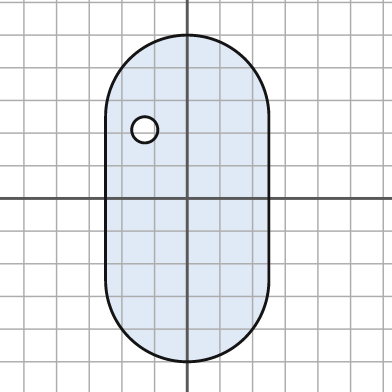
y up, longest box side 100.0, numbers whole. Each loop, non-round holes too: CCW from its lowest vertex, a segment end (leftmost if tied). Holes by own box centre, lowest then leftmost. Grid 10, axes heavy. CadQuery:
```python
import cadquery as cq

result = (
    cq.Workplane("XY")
    .moveTo(-25.0, -25.0)
    .threePointArc((0.0, -50.0), (25.0, -25.0))
    .lineTo(25.0, 25.0)
    .threePointArc((0.0, 50.0), (-25.0, 25.0))
    .close()
    .moveTo(-13.0, 21.0)
    .circle(4.0)
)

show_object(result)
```